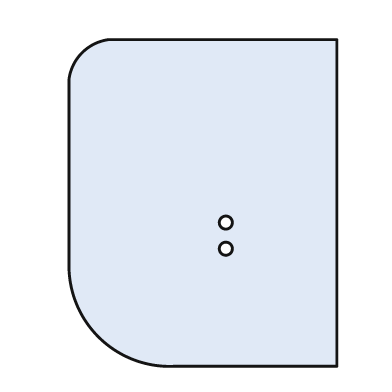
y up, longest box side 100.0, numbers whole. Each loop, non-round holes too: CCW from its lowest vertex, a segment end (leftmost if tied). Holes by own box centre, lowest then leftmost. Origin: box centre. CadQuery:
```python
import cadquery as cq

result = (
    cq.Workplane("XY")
    .moveTo(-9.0, -50.0)
    .lineTo(41.0, -50.0)
    .lineTo(41.0, 50.0)
    .lineTo(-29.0, 50.0)
    .threePointArc((-37.0, 46.0), (-41.0, 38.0))
    .lineTo(-41.0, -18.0)
    .threePointArc((-32.0, -41.0), (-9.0, -50.0))
    .close()
    .moveTo(7.0, -14.0)
    .circle(2.0)
    .moveTo(7.0, -6.0)
    .circle(2.0)
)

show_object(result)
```